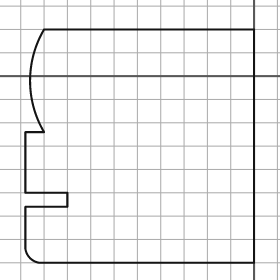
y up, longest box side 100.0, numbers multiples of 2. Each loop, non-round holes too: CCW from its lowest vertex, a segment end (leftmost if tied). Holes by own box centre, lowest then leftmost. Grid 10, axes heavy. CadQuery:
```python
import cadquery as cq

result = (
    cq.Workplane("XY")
    .moveTo(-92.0, -80.0)
    .lineTo(0.0, -80.0)
    .lineTo(0.0, 20.0)
    .lineTo(-90.0, 20.0)
    .threePointArc((-96.0, -2.0), (-90.0, -24.0))
    .lineTo(-98.0, -24.0)
    .lineTo(-98.0, -50.0)
    .lineTo(-80.0, -50.0)
    .lineTo(-80.0, -56.0)
    .lineTo(-98.0, -56.0)
    .lineTo(-98.0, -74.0)
    .threePointArc((-96.0, -78.0), (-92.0, -80.0))
    .close()
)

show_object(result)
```